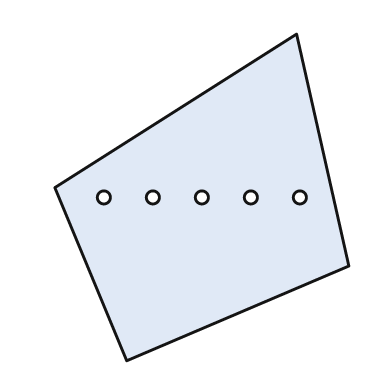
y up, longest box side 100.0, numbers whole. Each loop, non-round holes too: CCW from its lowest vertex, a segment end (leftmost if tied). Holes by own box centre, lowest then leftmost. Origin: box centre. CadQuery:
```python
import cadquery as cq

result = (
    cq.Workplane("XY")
    .moveTo(-23.0, -50.0)
    .lineTo(45.0, -21.0)
    .lineTo(29.0, 50.0)
    .lineTo(-45.0, 3.0)
    .close()
    .moveTo(-30.0, 0.0)
    .circle(2.0)
    .moveTo(-15.0, 0.0)
    .circle(2.0)
    .moveTo(0.0, 0.0)
    .circle(2.0)
    .moveTo(15.0, 0.0)
    .circle(2.0)
    .moveTo(30.0, 0.0)
    .circle(2.0)
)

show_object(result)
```